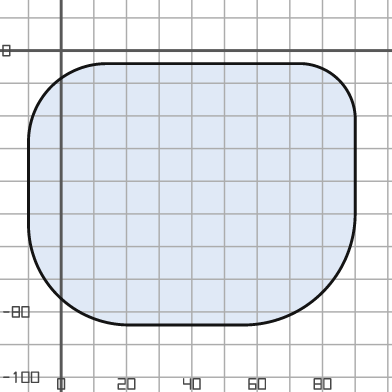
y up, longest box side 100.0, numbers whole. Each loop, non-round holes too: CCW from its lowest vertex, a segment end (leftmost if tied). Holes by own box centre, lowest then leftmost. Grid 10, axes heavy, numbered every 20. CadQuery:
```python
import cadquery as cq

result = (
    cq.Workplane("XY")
    .moveTo(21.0, -84.0)
    .lineTo(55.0, -84.0)
    .threePointArc((80.0, -74.0), (90.0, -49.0))
    .lineTo(90.0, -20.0)
    .threePointArc((85.0, -9.0), (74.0, -4.0))
    .lineTo(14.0, -4.0)
    .threePointArc((-3.0, -11.0), (-10.0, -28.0))
    .lineTo(-10.0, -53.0)
    .threePointArc((-1.0, -75.0), (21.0, -84.0))
    .close()
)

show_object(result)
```